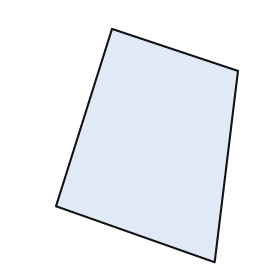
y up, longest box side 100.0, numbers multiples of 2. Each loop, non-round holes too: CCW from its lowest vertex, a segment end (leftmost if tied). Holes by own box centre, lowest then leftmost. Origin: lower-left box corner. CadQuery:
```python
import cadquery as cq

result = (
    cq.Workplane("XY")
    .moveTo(68.0, 0.0)
    .lineTo(78.0, 82.0)
    .lineTo(24.0, 100.0)
    .lineTo(0.0, 24.0)
    .close()
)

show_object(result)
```